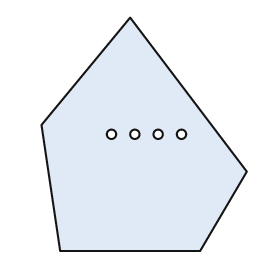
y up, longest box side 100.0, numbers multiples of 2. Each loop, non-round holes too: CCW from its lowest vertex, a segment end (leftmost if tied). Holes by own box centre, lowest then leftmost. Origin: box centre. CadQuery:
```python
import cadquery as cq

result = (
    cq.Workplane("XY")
    .moveTo(-36.0, -50.0)
    .lineTo(24.0, -50.0)
    .lineTo(44.0, -16.0)
    .lineTo(-6.0, 50.0)
    .lineTo(-44.0, 4.0)
    .close()
    .moveTo(-14.0, 0.0)
    .circle(2.0)
    .moveTo(-4.0, 0.0)
    .circle(2.0)
    .moveTo(6.0, 0.0)
    .circle(2.0)
    .moveTo(16.0, 0.0)
    .circle(2.0)
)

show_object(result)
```